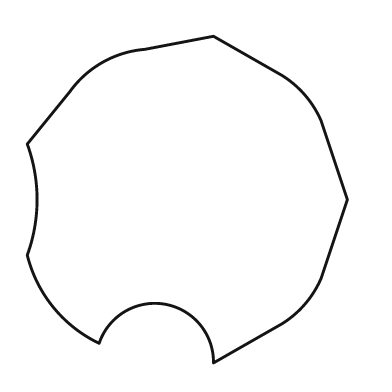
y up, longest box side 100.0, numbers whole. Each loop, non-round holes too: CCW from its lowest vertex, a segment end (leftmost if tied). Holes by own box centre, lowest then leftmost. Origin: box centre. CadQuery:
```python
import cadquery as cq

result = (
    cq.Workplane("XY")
    .moveTo(8.0, -50.0)
    .lineTo(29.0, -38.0)
    .threePointArc((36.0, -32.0), (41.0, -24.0))
    .lineTo(49.0, 0.0)
    .lineTo(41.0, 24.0)
    .threePointArc((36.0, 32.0), (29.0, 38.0))
    .lineTo(8.0, 50.0)
    .lineTo(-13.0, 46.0)
    .threePointArc((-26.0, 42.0), (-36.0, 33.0))
    .lineTo(-49.0, 17.0)
    .threePointArc((-46.0, 0.0), (-49.0, -17.0))
    .threePointArc((-41.0, -33.0), (-27.0, -44.0))
    .threePointArc((-7.0, -32.0), (8.0, -50.0))
    .close()
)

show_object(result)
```